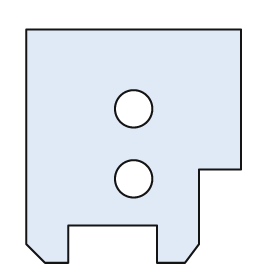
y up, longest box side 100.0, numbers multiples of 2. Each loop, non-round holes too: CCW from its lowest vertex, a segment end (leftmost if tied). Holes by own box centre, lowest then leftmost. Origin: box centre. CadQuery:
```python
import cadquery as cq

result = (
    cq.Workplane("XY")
    .moveTo(-38.0, -50.0)
    .lineTo(-28.0, -50.0)
    .lineTo(-28.0, -34.0)
    .lineTo(10.0, -34.0)
    .lineTo(10.0, -50.0)
    .lineTo(22.0, -50.0)
    .lineTo(28.0, -42.0)
    .lineTo(28.0, -10.0)
    .lineTo(46.0, -10.0)
    .lineTo(46.0, 50.0)
    .lineTo(-46.0, 50.0)
    .lineTo(-46.0, -42.0)
    .close()
    .moveTo(0.0, -14.0)
    .circle(8.0)
    .moveTo(0.0, 16.0)
    .circle(8.0)
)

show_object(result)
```